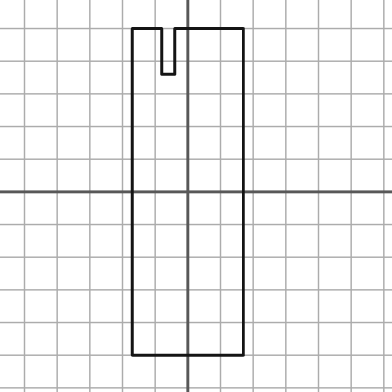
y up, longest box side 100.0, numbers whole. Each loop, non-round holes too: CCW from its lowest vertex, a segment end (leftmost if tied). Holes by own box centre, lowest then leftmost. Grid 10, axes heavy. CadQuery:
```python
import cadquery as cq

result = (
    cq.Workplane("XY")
    .moveTo(-17.0, -50.0)
    .lineTo(17.0, -50.0)
    .lineTo(17.0, 50.0)
    .lineTo(-4.0, 50.0)
    .lineTo(-4.0, 36.0)
    .lineTo(-8.0, 36.0)
    .lineTo(-8.0, 50.0)
    .lineTo(-17.0, 50.0)
    .close()
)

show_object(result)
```